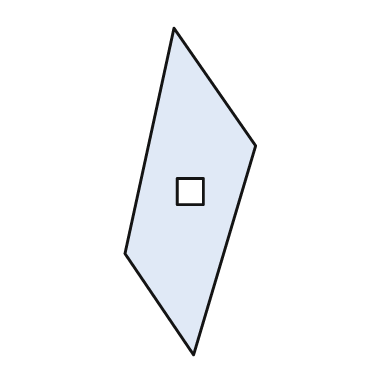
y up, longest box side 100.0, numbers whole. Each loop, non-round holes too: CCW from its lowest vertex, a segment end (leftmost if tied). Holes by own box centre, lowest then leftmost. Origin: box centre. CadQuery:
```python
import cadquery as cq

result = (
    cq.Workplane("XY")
    .moveTo(1.0, -50.0)
    .lineTo(20.0, 14.0)
    .lineTo(-5.0, 50.0)
    .lineTo(-20.0, -19.0)
    .close()
    .moveTo(-4.0, -4.0)
    .lineTo(4.0, -4.0)
    .lineTo(4.0, 4.0)
    .lineTo(-4.0, 4.0)
    .close()
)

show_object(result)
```